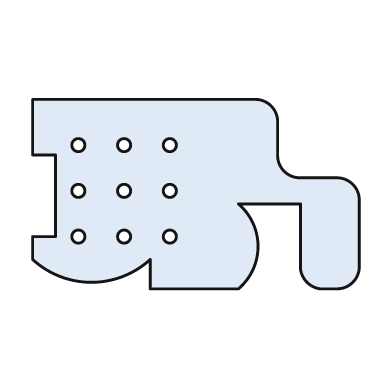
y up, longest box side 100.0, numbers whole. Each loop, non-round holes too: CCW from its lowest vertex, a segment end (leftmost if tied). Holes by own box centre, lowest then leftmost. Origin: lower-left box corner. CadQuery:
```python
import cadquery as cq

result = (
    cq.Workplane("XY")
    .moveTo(36.0, 0.0)
    .lineTo(63.0, 0.0)
    .threePointArc((69.0, 13.0), (63.0, 26.0))
    .lineTo(82.0, 26.0)
    .lineTo(82.0, 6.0)
    .threePointArc((84.0, 2.0), (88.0, 0.0))
    .lineTo(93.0, 0.0)
    .threePointArc((98.0, 2.0), (100.0, 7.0))
    .lineTo(100.0, 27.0)
    .threePointArc((98.0, 32.0), (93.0, 34.0))
    .lineTo(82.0, 34.0)
    .threePointArc((77.0, 36.0), (75.0, 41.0))
    .lineTo(75.0, 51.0)
    .threePointArc((73.0, 56.0), (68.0, 58.0))
    .lineTo(0.0, 58.0)
    .lineTo(0.0, 41.0)
    .lineTo(7.0, 41.0)
    .lineTo(7.0, 16.0)
    .lineTo(0.0, 16.0)
    .lineTo(0.0, 9.0)
    .threePointArc((18.0, 2.0), (36.0, 9.0))
    .close()
    .moveTo(14.0, 16.0)
    .circle(2.0)
    .moveTo(28.0, 16.0)
    .circle(2.0)
    .moveTo(42.0, 16.0)
    .circle(2.0)
    .moveTo(14.0, 30.0)
    .circle(2.0)
    .moveTo(28.0, 30.0)
    .circle(2.0)
    .moveTo(42.0, 30.0)
    .circle(2.0)
    .moveTo(14.0, 44.0)
    .circle(2.0)
    .moveTo(28.0, 44.0)
    .circle(2.0)
    .moveTo(42.0, 44.0)
    .circle(2.0)
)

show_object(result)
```